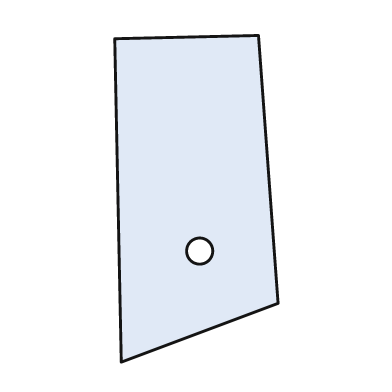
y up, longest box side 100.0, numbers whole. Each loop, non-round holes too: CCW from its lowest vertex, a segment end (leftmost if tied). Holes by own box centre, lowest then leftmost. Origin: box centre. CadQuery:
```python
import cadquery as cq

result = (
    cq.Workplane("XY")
    .moveTo(-23.0, -50.0)
    .lineTo(25.0, -32.0)
    .lineTo(19.0, 50.0)
    .lineTo(-25.0, 49.0)
    .close()
    .moveTo(1.0, -16.0)
    .circle(4.0)
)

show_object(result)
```